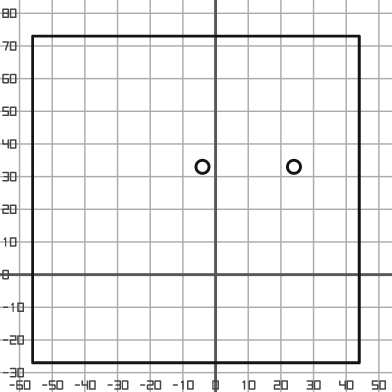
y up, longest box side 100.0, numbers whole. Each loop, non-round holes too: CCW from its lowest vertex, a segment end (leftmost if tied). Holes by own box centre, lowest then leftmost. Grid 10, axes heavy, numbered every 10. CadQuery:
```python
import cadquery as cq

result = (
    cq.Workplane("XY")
    .moveTo(-56.0, -27.0)
    .lineTo(44.0, -27.0)
    .lineTo(44.0, 73.0)
    .lineTo(-56.0, 73.0)
    .close()
    .moveTo(-4.0, 33.0)
    .circle(2.0)
    .moveTo(24.0, 33.0)
    .circle(2.0)
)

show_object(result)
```